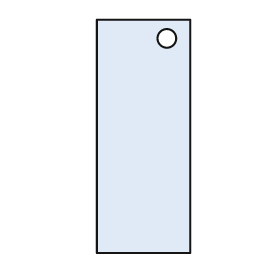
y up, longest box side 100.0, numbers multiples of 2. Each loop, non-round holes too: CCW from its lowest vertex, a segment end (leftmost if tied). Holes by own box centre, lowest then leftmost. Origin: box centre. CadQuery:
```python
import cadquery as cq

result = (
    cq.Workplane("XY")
    .moveTo(-20.0, -50.0)
    .lineTo(20.0, -50.0)
    .lineTo(20.0, 50.0)
    .lineTo(-20.0, 50.0)
    .close()
    .moveTo(10.0, 42.0)
    .circle(4.0)
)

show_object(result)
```